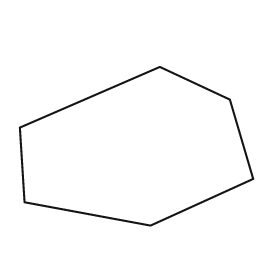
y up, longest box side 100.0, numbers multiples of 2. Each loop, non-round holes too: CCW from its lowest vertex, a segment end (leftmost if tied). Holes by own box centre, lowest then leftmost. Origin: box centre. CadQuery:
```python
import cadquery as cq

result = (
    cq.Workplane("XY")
    .moveTo(6.0, -34.0)
    .lineTo(50.0, -14.0)
    .lineTo(40.0, 20.0)
    .lineTo(10.0, 34.0)
    .lineTo(-50.0, 8.0)
    .lineTo(-48.0, -24.0)
    .close()
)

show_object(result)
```